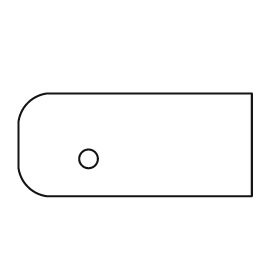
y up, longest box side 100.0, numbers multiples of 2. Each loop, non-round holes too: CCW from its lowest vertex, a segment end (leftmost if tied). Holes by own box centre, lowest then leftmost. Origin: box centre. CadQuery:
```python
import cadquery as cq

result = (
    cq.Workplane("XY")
    .moveTo(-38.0, -22.0)
    .lineTo(50.0, -22.0)
    .lineTo(50.0, 22.0)
    .lineTo(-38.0, 22.0)
    .threePointArc((-46.0, 18.0), (-50.0, 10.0))
    .lineTo(-50.0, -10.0)
    .threePointArc((-46.0, -18.0), (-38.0, -22.0))
    .close()
    .moveTo(-20.0, -6.0)
    .circle(4.0)
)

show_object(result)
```